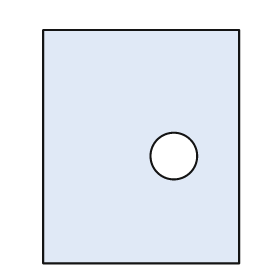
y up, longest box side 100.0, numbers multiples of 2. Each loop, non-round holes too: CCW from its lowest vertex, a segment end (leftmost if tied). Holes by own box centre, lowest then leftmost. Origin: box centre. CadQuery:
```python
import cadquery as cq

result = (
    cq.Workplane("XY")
    .moveTo(-42.0, -50.0)
    .lineTo(42.0, -50.0)
    .lineTo(42.0, 50.0)
    .lineTo(-42.0, 50.0)
    .close()
    .moveTo(14.0, -4.0)
    .circle(10.0)
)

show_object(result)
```